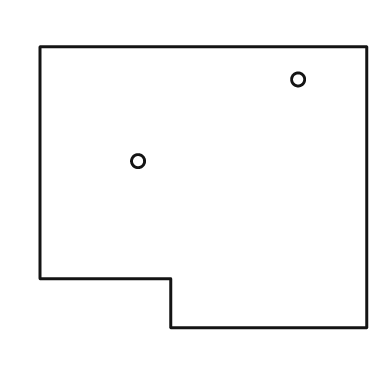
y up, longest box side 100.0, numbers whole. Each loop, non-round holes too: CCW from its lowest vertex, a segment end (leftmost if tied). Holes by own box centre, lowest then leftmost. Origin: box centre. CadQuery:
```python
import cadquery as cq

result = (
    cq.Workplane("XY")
    .moveTo(-10.0, -43.0)
    .lineTo(50.0, -43.0)
    .lineTo(50.0, 43.0)
    .lineTo(-50.0, 43.0)
    .lineTo(-50.0, -28.0)
    .lineTo(-10.0, -28.0)
    .close()
    .moveTo(-20.0, 8.0)
    .circle(2.0)
    .moveTo(29.0, 33.0)
    .circle(2.0)
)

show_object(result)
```